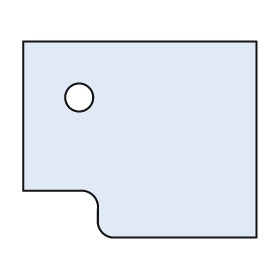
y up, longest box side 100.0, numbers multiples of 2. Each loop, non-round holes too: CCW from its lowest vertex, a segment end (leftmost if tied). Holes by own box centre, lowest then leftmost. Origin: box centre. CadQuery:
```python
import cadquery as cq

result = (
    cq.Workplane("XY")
    .moveTo(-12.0, -42.0)
    .lineTo(50.0, -42.0)
    .lineTo(50.0, 42.0)
    .lineTo(-50.0, 42.0)
    .lineTo(-50.0, -22.0)
    .lineTo(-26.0, -22.0)
    .threePointArc((-20.0, -24.0), (-18.0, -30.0))
    .lineTo(-18.0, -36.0)
    .threePointArc((-16.0, -40.0), (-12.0, -42.0))
    .close()
    .moveTo(-26.0, 18.0)
    .circle(6.0)
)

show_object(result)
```